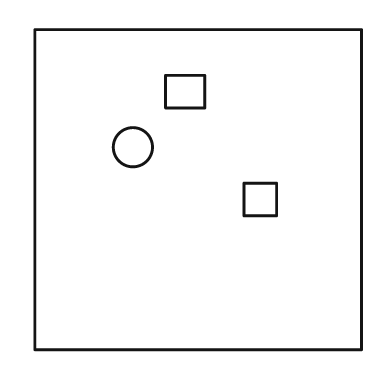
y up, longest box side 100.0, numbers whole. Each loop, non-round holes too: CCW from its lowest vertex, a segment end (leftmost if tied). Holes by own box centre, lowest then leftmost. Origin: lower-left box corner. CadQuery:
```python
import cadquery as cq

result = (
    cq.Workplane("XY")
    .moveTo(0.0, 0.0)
    .lineTo(100.0, 0.0)
    .lineTo(100.0, 98.0)
    .lineTo(0.0, 98.0)
    .close()
    .moveTo(64.0, 41.0)
    .lineTo(74.0, 41.0)
    .lineTo(74.0, 51.0)
    .lineTo(64.0, 51.0)
    .close()
    .moveTo(30.0, 62.0)
    .circle(6.0)
    .moveTo(40.0, 74.0)
    .lineTo(52.0, 74.0)
    .lineTo(52.0, 84.0)
    .lineTo(40.0, 84.0)
    .close()
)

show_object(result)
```